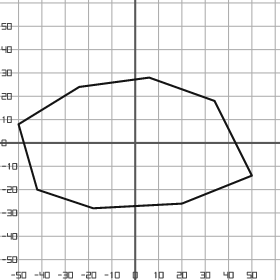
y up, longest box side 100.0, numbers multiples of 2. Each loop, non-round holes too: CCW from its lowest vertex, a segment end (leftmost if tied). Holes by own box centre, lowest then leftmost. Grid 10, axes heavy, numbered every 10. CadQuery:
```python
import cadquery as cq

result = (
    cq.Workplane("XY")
    .moveTo(-18.0, -28.0)
    .lineTo(20.0, -26.0)
    .lineTo(50.0, -14.0)
    .lineTo(34.0, 18.0)
    .lineTo(6.0, 28.0)
    .lineTo(-24.0, 24.0)
    .lineTo(-50.0, 8.0)
    .lineTo(-42.0, -20.0)
    .close()
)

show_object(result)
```